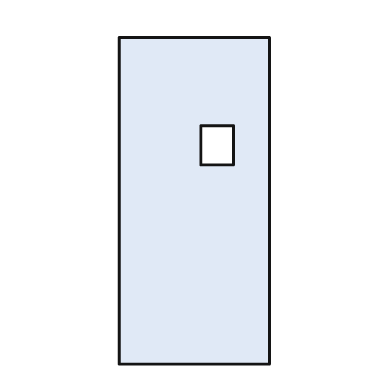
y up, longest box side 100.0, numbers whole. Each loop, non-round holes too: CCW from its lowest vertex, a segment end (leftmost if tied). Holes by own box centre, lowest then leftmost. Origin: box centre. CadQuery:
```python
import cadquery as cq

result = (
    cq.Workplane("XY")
    .moveTo(-23.0, -50.0)
    .lineTo(23.0, -50.0)
    .lineTo(23.0, 50.0)
    .lineTo(-23.0, 50.0)
    .close()
    .moveTo(2.0, 11.0)
    .lineTo(12.0, 11.0)
    .lineTo(12.0, 23.0)
    .lineTo(2.0, 23.0)
    .close()
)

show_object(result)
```